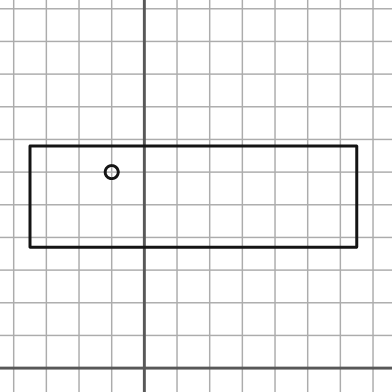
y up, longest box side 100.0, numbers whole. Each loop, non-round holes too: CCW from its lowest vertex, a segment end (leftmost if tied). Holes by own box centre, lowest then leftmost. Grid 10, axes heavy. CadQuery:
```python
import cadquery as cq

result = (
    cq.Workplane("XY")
    .moveTo(-35.0, 37.0)
    .lineTo(65.0, 37.0)
    .lineTo(65.0, 68.0)
    .lineTo(-35.0, 68.0)
    .close()
    .moveTo(-10.0, 60.0)
    .circle(2.0)
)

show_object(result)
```